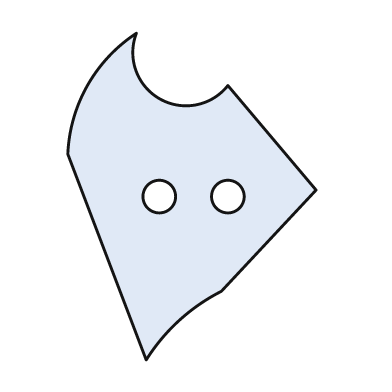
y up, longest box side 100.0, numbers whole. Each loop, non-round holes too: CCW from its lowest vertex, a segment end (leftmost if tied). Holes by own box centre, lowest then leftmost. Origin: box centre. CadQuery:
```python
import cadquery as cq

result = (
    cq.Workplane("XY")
    .moveTo(-14.0, -50.0)
    .threePointArc((-4.0, -38.0), (9.0, -29.0))
    .lineTo(38.0, 2.0)
    .lineTo(11.0, 34.0)
    .threePointArc((-10.0, 30.0), (-17.0, 50.0))
    .threePointArc((-32.0, 34.0), (-38.0, 13.0))
    .close()
    .moveTo(-10.0, 0.0)
    .circle(5.0)
    .moveTo(11.0, 0.0)
    .circle(5.0)
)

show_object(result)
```